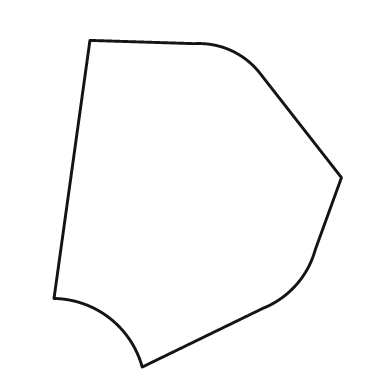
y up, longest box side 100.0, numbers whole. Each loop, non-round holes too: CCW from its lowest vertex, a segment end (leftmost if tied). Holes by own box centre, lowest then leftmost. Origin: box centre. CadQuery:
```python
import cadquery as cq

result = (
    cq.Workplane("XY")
    .moveTo(-17.0, -50.0)
    .lineTo(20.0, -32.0)
    .threePointArc((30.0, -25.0), (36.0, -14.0))
    .lineTo(44.0, 8.0)
    .lineTo(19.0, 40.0)
    .threePointArc((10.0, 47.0), (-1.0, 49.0))
    .lineTo(-33.0, 50.0)
    .lineTo(-44.0, -29.0)
    .threePointArc((-27.0, -35.0), (-17.0, -50.0))
    .close()
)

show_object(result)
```